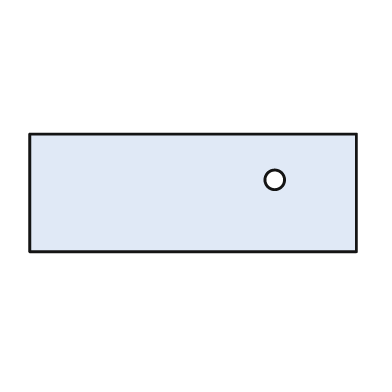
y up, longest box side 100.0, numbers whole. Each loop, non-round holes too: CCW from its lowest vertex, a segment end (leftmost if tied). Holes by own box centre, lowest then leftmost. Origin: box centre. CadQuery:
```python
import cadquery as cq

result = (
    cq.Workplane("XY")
    .moveTo(-50.0, -18.0)
    .lineTo(50.0, -18.0)
    .lineTo(50.0, 18.0)
    .lineTo(-50.0, 18.0)
    .close()
    .moveTo(25.0, 4.0)
    .circle(3.0)
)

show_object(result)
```